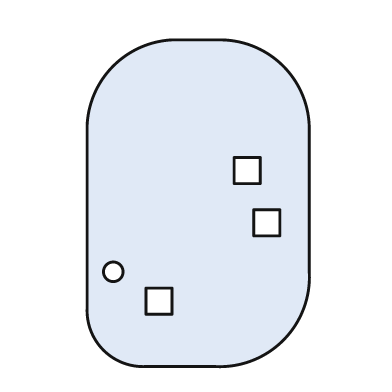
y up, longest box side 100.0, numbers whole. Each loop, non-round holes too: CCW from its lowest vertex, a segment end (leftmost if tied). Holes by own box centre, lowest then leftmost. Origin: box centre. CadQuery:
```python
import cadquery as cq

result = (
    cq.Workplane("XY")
    .moveTo(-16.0, -50.0)
    .lineTo(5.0, -50.0)
    .threePointArc((26.0, -42.0), (34.0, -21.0))
    .lineTo(34.0, 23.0)
    .threePointArc((26.0, 42.0), (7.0, 50.0))
    .lineTo(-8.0, 50.0)
    .threePointArc((-26.0, 42.0), (-34.0, 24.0))
    .lineTo(-34.0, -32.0)
    .threePointArc((-29.0, -45.0), (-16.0, -50.0))
    .close()
    .moveTo(-16.0, -34.0)
    .lineTo(-8.0, -34.0)
    .lineTo(-8.0, -26.0)
    .lineTo(-16.0, -26.0)
    .close()
    .moveTo(-26.0, -21.0)
    .circle(3.0)
    .moveTo(17.0, -10.0)
    .lineTo(25.0, -10.0)
    .lineTo(25.0, -2.0)
    .lineTo(17.0, -2.0)
    .close()
    .moveTo(11.0, 6.0)
    .lineTo(19.0, 6.0)
    .lineTo(19.0, 14.0)
    .lineTo(11.0, 14.0)
    .close()
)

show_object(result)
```